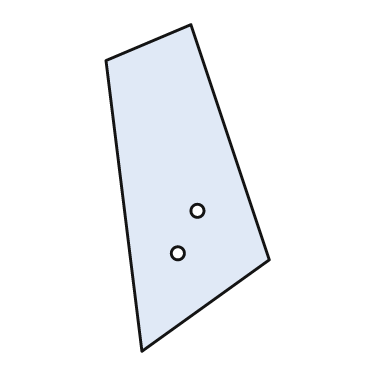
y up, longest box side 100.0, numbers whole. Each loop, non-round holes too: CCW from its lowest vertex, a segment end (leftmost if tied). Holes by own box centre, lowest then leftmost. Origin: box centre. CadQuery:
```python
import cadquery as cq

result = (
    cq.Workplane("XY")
    .moveTo(-14.0, -50.0)
    .lineTo(25.0, -22.0)
    .lineTo(1.0, 50.0)
    .lineTo(-25.0, 39.0)
    .close()
    .moveTo(-3.0, -20.0)
    .circle(2.0)
    .moveTo(3.0, -7.0)
    .circle(2.0)
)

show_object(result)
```